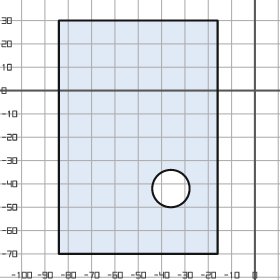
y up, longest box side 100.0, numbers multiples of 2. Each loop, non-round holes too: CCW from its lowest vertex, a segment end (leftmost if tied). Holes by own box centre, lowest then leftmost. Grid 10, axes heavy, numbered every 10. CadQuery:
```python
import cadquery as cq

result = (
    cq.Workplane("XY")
    .moveTo(-84.0, -70.0)
    .lineTo(-16.0, -70.0)
    .lineTo(-16.0, 30.0)
    .lineTo(-84.0, 30.0)
    .close()
    .moveTo(-36.0, -42.0)
    .circle(8.0)
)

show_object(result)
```